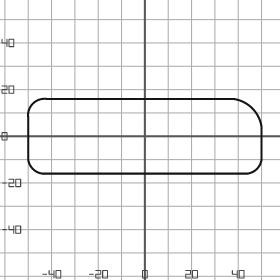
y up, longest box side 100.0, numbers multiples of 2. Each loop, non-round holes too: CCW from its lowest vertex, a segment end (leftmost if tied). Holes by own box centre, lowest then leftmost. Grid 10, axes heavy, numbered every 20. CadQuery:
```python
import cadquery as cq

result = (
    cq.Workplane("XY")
    .moveTo(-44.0, -16.0)
    .lineTo(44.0, -16.0)
    .threePointArc((48.0, -14.0), (50.0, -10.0))
    .lineTo(50.0, 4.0)
    .threePointArc((46.0, 12.0), (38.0, 16.0))
    .lineTo(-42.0, 16.0)
    .threePointArc((-48.0, 14.0), (-50.0, 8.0))
    .lineTo(-50.0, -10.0)
    .threePointArc((-48.0, -14.0), (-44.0, -16.0))
    .close()
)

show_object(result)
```